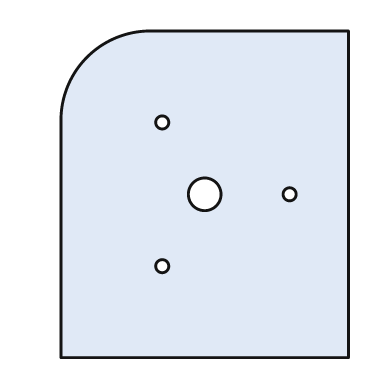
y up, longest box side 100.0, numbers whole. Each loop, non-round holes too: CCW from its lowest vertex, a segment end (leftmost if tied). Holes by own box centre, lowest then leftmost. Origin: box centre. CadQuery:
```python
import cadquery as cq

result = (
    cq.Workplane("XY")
    .moveTo(-44.0, -50.0)
    .lineTo(44.0, -50.0)
    .lineTo(44.0, 50.0)
    .lineTo(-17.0, 50.0)
    .threePointArc((-36.0, 42.0), (-44.0, 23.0))
    .close()
    .moveTo(-13.0, -22.0)
    .circle(2.0)
    .moveTo(0.0, 0.0)
    .circle(5.0)
    .moveTo(26.0, 0.0)
    .circle(2.0)
    .moveTo(-13.0, 22.0)
    .circle(2.0)
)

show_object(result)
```